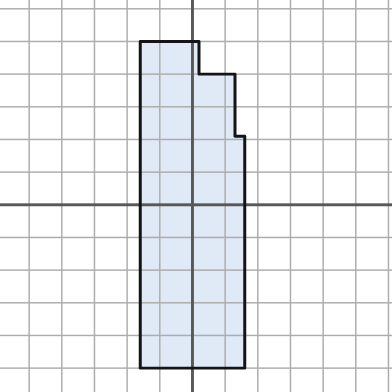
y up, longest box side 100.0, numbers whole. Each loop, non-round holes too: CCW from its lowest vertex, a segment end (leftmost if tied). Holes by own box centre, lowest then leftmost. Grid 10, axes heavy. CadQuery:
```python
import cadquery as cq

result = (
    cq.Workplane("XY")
    .moveTo(-16.0, -50.0)
    .lineTo(16.0, -50.0)
    .lineTo(16.0, 21.0)
    .lineTo(13.0, 21.0)
    .lineTo(13.0, 40.0)
    .lineTo(2.0, 40.0)
    .lineTo(2.0, 50.0)
    .lineTo(-16.0, 50.0)
    .close()
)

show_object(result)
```